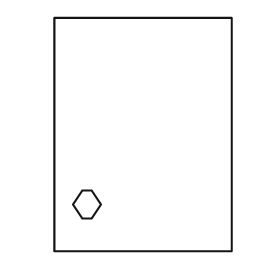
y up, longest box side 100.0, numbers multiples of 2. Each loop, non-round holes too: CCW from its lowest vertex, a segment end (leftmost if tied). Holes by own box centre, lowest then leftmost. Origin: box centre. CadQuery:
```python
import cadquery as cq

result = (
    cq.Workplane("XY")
    .moveTo(-38.0, -50.0)
    .lineTo(38.0, -50.0)
    .lineTo(38.0, 50.0)
    .lineTo(-38.0, 50.0)
    .close()
    .moveTo(-26.0, -36.0)
    .lineTo(-22.0, -36.0)
    .lineTo(-18.0, -30.0)
    .lineTo(-22.0, -24.0)
    .lineTo(-26.0, -24.0)
    .lineTo(-30.0, -30.0)
    .close()
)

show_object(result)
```